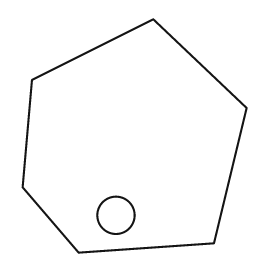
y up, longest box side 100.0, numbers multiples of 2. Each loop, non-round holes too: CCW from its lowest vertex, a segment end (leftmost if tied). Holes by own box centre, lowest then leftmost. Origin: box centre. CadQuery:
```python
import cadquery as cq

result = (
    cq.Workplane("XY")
    .moveTo(-24.0, -50.0)
    .lineTo(34.0, -46.0)
    .lineTo(48.0, 12.0)
    .lineTo(8.0, 50.0)
    .lineTo(-44.0, 24.0)
    .lineTo(-48.0, -22.0)
    .close()
    .moveTo(-8.0, -34.0)
    .circle(8.0)
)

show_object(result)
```